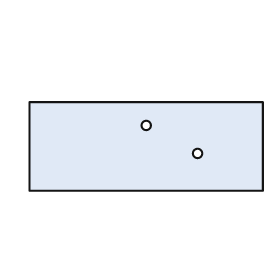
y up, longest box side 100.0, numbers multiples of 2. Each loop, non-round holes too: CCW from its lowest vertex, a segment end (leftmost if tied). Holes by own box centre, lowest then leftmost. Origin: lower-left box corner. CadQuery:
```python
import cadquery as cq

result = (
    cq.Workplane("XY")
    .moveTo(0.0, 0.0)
    .lineTo(100.0, 0.0)
    .lineTo(100.0, 38.0)
    .lineTo(0.0, 38.0)
    .close()
    .moveTo(72.0, 16.0)
    .circle(2.0)
    .moveTo(50.0, 28.0)
    .circle(2.0)
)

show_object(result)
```